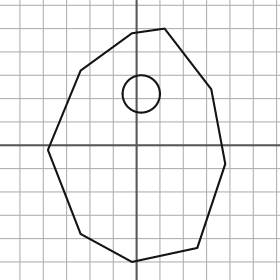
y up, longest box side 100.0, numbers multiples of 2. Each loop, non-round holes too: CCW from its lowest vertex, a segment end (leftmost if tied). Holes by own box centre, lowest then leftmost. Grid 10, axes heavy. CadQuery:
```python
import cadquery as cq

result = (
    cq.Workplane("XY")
    .moveTo(-2.0, -50.0)
    .lineTo(26.0, -44.0)
    .lineTo(38.0, -8.0)
    .lineTo(32.0, 24.0)
    .lineTo(12.0, 50.0)
    .lineTo(-2.0, 48.0)
    .lineTo(-24.0, 32.0)
    .lineTo(-38.0, -2.0)
    .lineTo(-24.0, -38.0)
    .close()
    .moveTo(2.0, 22.0)
    .circle(8.0)
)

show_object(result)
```